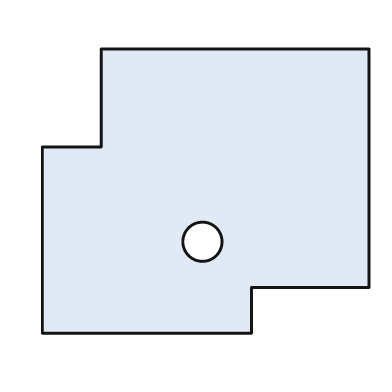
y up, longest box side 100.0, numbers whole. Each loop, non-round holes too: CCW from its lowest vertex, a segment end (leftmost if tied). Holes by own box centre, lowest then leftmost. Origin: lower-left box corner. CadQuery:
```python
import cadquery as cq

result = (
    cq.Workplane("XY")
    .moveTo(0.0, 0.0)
    .lineTo(64.0, 0.0)
    .lineTo(64.0, 14.0)
    .lineTo(100.0, 14.0)
    .lineTo(100.0, 87.0)
    .lineTo(18.0, 87.0)
    .lineTo(18.0, 57.0)
    .lineTo(0.0, 57.0)
    .close()
    .moveTo(49.0, 28.0)
    .circle(6.0)
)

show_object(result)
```